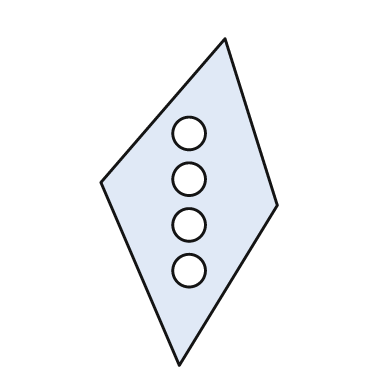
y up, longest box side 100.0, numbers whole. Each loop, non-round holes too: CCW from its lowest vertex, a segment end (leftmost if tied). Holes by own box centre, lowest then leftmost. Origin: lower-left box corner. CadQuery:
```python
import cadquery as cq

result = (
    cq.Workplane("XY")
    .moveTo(24.0, 0.0)
    .lineTo(54.0, 49.0)
    .lineTo(38.0, 100.0)
    .lineTo(0.0, 56.0)
    .close()
    .moveTo(27.0, 29.0)
    .circle(5.0)
    .moveTo(27.0, 43.0)
    .circle(5.0)
    .moveTo(27.0, 57.0)
    .circle(5.0)
    .moveTo(27.0, 71.0)
    .circle(5.0)
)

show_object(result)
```